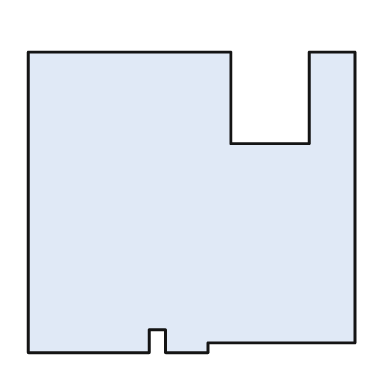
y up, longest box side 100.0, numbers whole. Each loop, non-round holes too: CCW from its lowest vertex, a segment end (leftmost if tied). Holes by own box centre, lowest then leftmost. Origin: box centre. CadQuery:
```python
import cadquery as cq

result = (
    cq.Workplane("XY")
    .moveTo(-50.0, -46.0)
    .lineTo(-13.0, -46.0)
    .lineTo(-13.0, -39.0)
    .lineTo(-8.0, -39.0)
    .lineTo(-8.0, -46.0)
    .lineTo(5.0, -46.0)
    .lineTo(5.0, -43.0)
    .lineTo(50.0, -43.0)
    .lineTo(50.0, 46.0)
    .lineTo(36.0, 46.0)
    .lineTo(36.0, 18.0)
    .lineTo(12.0, 18.0)
    .lineTo(12.0, 46.0)
    .lineTo(-50.0, 46.0)
    .close()
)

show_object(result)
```